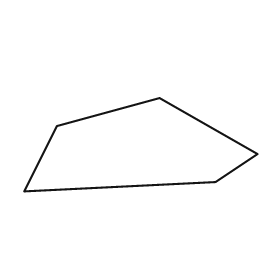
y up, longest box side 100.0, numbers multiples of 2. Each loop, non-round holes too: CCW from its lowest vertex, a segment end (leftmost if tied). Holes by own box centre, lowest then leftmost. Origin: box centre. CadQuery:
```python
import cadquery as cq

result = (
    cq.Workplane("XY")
    .moveTo(-50.0, -20.0)
    .lineTo(32.0, -16.0)
    .lineTo(50.0, -4.0)
    .lineTo(8.0, 20.0)
    .lineTo(-36.0, 8.0)
    .close()
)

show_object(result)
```